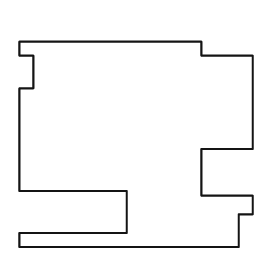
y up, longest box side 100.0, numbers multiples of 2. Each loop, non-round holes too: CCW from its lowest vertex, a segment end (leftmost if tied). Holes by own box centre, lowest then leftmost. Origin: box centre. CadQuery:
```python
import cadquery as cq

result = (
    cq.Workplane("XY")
    .moveTo(-50.0, -44.0)
    .lineTo(44.0, -44.0)
    .lineTo(44.0, -30.0)
    .lineTo(50.0, -30.0)
    .lineTo(50.0, -22.0)
    .lineTo(28.0, -22.0)
    .lineTo(28.0, -2.0)
    .lineTo(50.0, -2.0)
    .lineTo(50.0, 38.0)
    .lineTo(28.0, 38.0)
    .lineTo(28.0, 44.0)
    .lineTo(-50.0, 44.0)
    .lineTo(-50.0, 38.0)
    .lineTo(-44.0, 38.0)
    .lineTo(-44.0, 24.0)
    .lineTo(-50.0, 24.0)
    .lineTo(-50.0, -20.0)
    .lineTo(-4.0, -20.0)
    .lineTo(-4.0, -38.0)
    .lineTo(-50.0, -38.0)
    .close()
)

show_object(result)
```